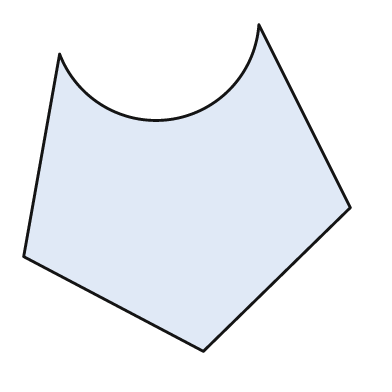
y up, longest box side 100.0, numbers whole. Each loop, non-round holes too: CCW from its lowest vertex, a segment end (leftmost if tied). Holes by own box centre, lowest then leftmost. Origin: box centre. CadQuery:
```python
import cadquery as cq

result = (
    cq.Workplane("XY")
    .moveTo(5.0, -50.0)
    .lineTo(50.0, -6.0)
    .lineTo(22.0, 50.0)
    .threePointArc((-5.0, 21.0), (-39.0, 41.0))
    .lineTo(-50.0, -21.0)
    .close()
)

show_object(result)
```